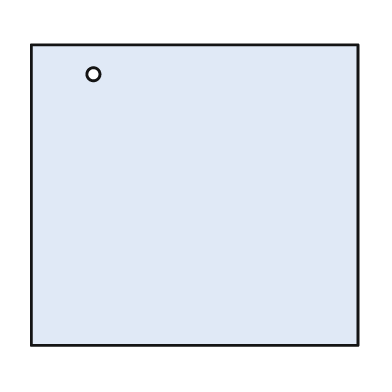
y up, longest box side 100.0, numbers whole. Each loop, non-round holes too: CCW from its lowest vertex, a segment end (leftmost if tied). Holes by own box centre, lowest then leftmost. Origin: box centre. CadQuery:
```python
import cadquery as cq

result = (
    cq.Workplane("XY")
    .moveTo(-50.0, -46.0)
    .lineTo(50.0, -46.0)
    .lineTo(50.0, 46.0)
    .lineTo(-50.0, 46.0)
    .close()
    .moveTo(-31.0, 37.0)
    .circle(2.0)
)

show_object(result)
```